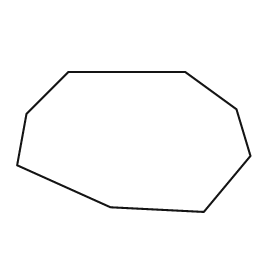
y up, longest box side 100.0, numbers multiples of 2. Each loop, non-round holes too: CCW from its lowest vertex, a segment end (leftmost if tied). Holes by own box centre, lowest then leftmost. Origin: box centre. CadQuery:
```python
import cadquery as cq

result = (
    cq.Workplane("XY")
    .moveTo(30.0, -30.0)
    .lineTo(50.0, -6.0)
    .lineTo(44.0, 14.0)
    .lineTo(22.0, 30.0)
    .lineTo(-28.0, 30.0)
    .lineTo(-46.0, 12.0)
    .lineTo(-50.0, -10.0)
    .lineTo(-10.0, -28.0)
    .close()
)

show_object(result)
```